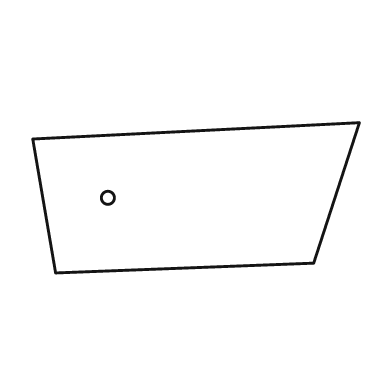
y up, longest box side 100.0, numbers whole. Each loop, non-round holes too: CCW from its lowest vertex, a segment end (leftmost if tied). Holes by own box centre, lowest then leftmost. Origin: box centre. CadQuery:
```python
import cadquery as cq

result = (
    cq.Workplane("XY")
    .moveTo(-43.0, -23.0)
    .lineTo(36.0, -20.0)
    .lineTo(50.0, 23.0)
    .lineTo(-50.0, 18.0)
    .close()
    .moveTo(-27.0, 0.0)
    .circle(2.0)
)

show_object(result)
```